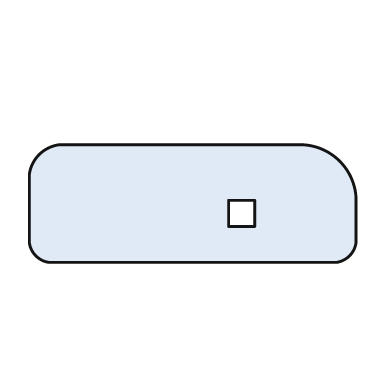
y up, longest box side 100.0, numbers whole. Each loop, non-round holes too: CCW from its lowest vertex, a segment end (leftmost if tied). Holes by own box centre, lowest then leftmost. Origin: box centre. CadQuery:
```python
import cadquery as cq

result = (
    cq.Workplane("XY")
    .moveTo(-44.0, -18.0)
    .lineTo(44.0, -18.0)
    .threePointArc((48.0, -16.0), (50.0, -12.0))
    .lineTo(50.0, 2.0)
    .threePointArc((45.0, 13.0), (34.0, 18.0))
    .lineTo(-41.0, 18.0)
    .threePointArc((-47.0, 15.0), (-50.0, 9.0))
    .lineTo(-50.0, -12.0)
    .threePointArc((-48.0, -16.0), (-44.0, -18.0))
    .close()
    .moveTo(11.0, -7.0)
    .lineTo(19.0, -7.0)
    .lineTo(19.0, 1.0)
    .lineTo(11.0, 1.0)
    .close()
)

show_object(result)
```